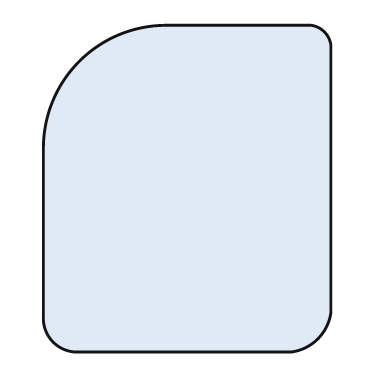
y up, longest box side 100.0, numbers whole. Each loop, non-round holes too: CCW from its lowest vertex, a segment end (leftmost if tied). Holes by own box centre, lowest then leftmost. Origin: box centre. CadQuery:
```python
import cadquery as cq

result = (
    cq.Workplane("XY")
    .moveTo(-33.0, -50.0)
    .lineTo(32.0, -50.0)
    .threePointArc((40.0, -46.0), (44.0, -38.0))
    .lineTo(44.0, 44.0)
    .threePointArc((42.0, 48.0), (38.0, 50.0))
    .lineTo(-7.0, 50.0)
    .threePointArc((-33.0, 39.0), (-44.0, 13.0))
    .lineTo(-44.0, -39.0)
    .threePointArc((-41.0, -47.0), (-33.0, -50.0))
    .close()
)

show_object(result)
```